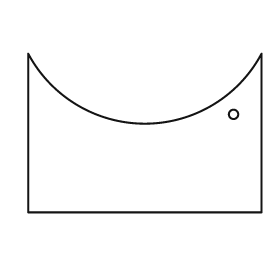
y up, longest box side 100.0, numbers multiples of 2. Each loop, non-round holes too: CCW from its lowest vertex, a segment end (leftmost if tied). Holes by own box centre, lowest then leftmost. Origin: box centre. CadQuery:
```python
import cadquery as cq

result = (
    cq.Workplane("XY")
    .moveTo(-50.0, -34.0)
    .lineTo(50.0, -34.0)
    .lineTo(50.0, 34.0)
    .threePointArc((0.0, 4.0), (-50.0, 34.0))
    .close()
    .moveTo(38.0, 8.0)
    .circle(2.0)
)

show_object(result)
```